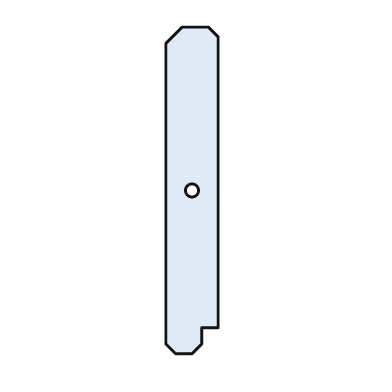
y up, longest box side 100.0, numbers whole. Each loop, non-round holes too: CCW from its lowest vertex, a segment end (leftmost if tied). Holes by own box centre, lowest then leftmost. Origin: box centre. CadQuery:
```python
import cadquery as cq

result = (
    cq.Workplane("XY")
    .moveTo(-5.0, -50.0)
    .lineTo(0.0, -50.0)
    .lineTo(3.0, -47.0)
    .lineTo(3.0, -42.0)
    .lineTo(8.0, -42.0)
    .lineTo(8.0, 47.0)
    .lineTo(5.0, 50.0)
    .lineTo(-3.0, 50.0)
    .lineTo(-8.0, 45.0)
    .lineTo(-8.0, -47.0)
    .close()
    .moveTo(0.0, 0.0)
    .circle(2.0)
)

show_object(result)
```